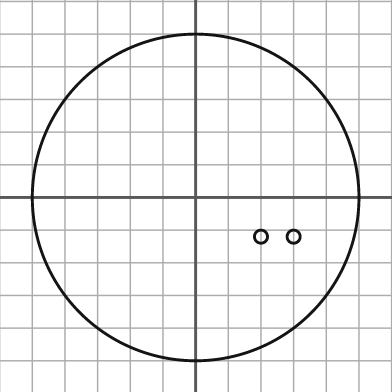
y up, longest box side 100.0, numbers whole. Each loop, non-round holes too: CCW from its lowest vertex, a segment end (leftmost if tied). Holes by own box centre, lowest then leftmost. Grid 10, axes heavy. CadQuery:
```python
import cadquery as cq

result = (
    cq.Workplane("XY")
    .moveTo(0.0, 0.0)
    .circle(50.0)
    .moveTo(20.0, -12.0)
    .circle(2.0)
    .moveTo(30.0, -12.0)
    .circle(2.0)
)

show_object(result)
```